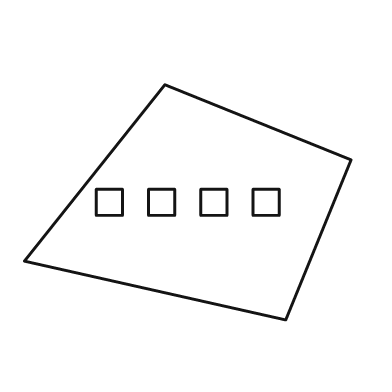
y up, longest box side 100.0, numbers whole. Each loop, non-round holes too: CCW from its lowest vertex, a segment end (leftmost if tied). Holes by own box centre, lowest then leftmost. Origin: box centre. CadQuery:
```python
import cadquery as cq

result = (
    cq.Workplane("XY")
    .moveTo(30.0, -36.0)
    .lineTo(50.0, 13.0)
    .lineTo(-7.0, 36.0)
    .lineTo(-50.0, -18.0)
    .close()
    .moveTo(-28.0, -4.0)
    .lineTo(-20.0, -4.0)
    .lineTo(-20.0, 4.0)
    .lineTo(-28.0, 4.0)
    .close()
    .moveTo(-12.0, -4.0)
    .lineTo(-4.0, -4.0)
    .lineTo(-4.0, 4.0)
    .lineTo(-12.0, 4.0)
    .close()
    .moveTo(4.0, -4.0)
    .lineTo(12.0, -4.0)
    .lineTo(12.0, 4.0)
    .lineTo(4.0, 4.0)
    .close()
    .moveTo(20.0, -4.0)
    .lineTo(28.0, -4.0)
    .lineTo(28.0, 4.0)
    .lineTo(20.0, 4.0)
    .close()
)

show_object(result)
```